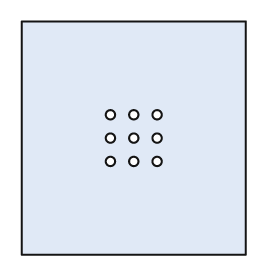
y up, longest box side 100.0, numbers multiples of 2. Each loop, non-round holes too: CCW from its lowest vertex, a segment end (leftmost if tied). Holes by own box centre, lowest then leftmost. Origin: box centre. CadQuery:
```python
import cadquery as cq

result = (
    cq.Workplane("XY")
    .moveTo(-48.0, -50.0)
    .lineTo(48.0, -50.0)
    .lineTo(48.0, 50.0)
    .lineTo(-48.0, 50.0)
    .close()
    .moveTo(-10.0, -10.0)
    .circle(2.0)
    .moveTo(0.0, -10.0)
    .circle(2.0)
    .moveTo(10.0, -10.0)
    .circle(2.0)
    .moveTo(-10.0, 0.0)
    .circle(2.0)
    .moveTo(0.0, 0.0)
    .circle(2.0)
    .moveTo(10.0, 0.0)
    .circle(2.0)
    .moveTo(-10.0, 10.0)
    .circle(2.0)
    .moveTo(0.0, 10.0)
    .circle(2.0)
    .moveTo(10.0, 10.0)
    .circle(2.0)
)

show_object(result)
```